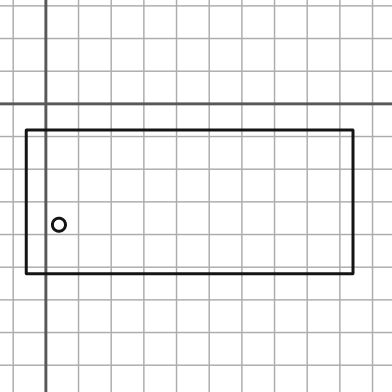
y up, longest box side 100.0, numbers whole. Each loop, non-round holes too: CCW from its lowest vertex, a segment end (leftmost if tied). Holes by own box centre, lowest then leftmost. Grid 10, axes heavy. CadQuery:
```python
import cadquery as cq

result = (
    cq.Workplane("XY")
    .moveTo(-6.0, -52.0)
    .lineTo(94.0, -52.0)
    .lineTo(94.0, -8.0)
    .lineTo(-6.0, -8.0)
    .close()
    .moveTo(4.0, -37.0)
    .circle(2.0)
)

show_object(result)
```